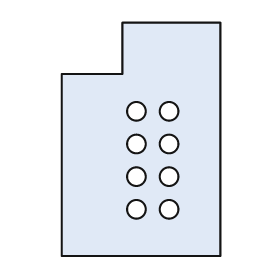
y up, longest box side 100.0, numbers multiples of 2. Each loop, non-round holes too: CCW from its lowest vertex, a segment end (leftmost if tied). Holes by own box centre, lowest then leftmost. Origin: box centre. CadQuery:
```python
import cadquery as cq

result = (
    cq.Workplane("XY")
    .moveTo(-34.0, -50.0)
    .lineTo(34.0, -50.0)
    .lineTo(34.0, 50.0)
    .lineTo(-8.0, 50.0)
    .lineTo(-8.0, 28.0)
    .lineTo(-34.0, 28.0)
    .close()
    .moveTo(-2.0, -30.0)
    .circle(4.0)
    .moveTo(12.0, -30.0)
    .circle(4.0)
    .moveTo(-2.0, -16.0)
    .circle(4.0)
    .moveTo(12.0, -16.0)
    .circle(4.0)
    .moveTo(-2.0, -2.0)
    .circle(4.0)
    .moveTo(12.0, -2.0)
    .circle(4.0)
    .moveTo(-2.0, 12.0)
    .circle(4.0)
    .moveTo(12.0, 12.0)
    .circle(4.0)
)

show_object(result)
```